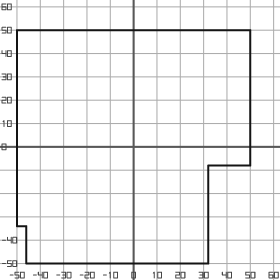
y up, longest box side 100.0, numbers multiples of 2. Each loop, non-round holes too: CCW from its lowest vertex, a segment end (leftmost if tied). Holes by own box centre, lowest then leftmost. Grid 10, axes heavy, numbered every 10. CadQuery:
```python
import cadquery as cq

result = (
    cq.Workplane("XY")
    .moveTo(-46.0, -50.0)
    .lineTo(32.0, -50.0)
    .lineTo(32.0, -8.0)
    .lineTo(50.0, -8.0)
    .lineTo(50.0, 50.0)
    .lineTo(-50.0, 50.0)
    .lineTo(-50.0, -34.0)
    .lineTo(-46.0, -34.0)
    .close()
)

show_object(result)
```